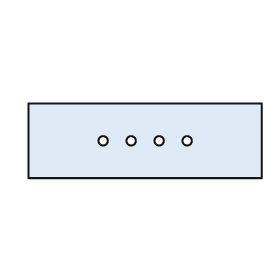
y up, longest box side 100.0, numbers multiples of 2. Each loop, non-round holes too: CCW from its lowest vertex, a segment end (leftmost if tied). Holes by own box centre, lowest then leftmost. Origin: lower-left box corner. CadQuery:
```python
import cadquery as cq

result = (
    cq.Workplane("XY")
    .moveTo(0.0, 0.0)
    .lineTo(100.0, 0.0)
    .lineTo(100.0, 32.0)
    .lineTo(0.0, 32.0)
    .close()
    .moveTo(32.0, 16.0)
    .circle(2.0)
    .moveTo(44.0, 16.0)
    .circle(2.0)
    .moveTo(56.0, 16.0)
    .circle(2.0)
    .moveTo(68.0, 16.0)
    .circle(2.0)
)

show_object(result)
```